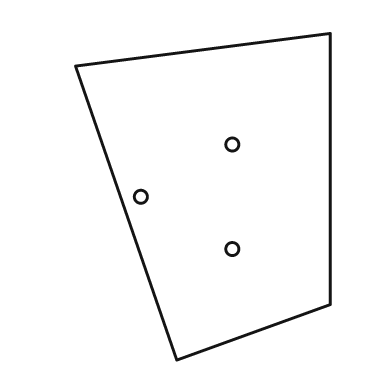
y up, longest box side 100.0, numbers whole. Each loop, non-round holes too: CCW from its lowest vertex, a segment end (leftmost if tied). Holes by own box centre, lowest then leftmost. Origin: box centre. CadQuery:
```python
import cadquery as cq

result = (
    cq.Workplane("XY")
    .moveTo(-8.0, -50.0)
    .lineTo(39.0, -33.0)
    .lineTo(39.0, 50.0)
    .lineTo(-39.0, 40.0)
    .close()
    .moveTo(9.0, -16.0)
    .circle(2.0)
    .moveTo(-19.0, 0.0)
    .circle(2.0)
    .moveTo(9.0, 16.0)
    .circle(2.0)
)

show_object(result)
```